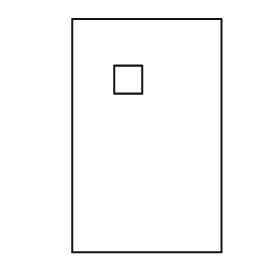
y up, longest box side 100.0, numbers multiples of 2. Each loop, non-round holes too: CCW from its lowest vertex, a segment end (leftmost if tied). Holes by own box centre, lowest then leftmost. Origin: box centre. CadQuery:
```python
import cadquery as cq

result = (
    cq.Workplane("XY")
    .moveTo(-32.0, -50.0)
    .lineTo(32.0, -50.0)
    .lineTo(32.0, 50.0)
    .lineTo(-32.0, 50.0)
    .close()
    .moveTo(-14.0, 18.0)
    .lineTo(-2.0, 18.0)
    .lineTo(-2.0, 30.0)
    .lineTo(-14.0, 30.0)
    .close()
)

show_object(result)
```